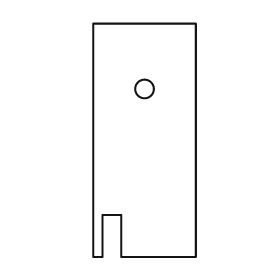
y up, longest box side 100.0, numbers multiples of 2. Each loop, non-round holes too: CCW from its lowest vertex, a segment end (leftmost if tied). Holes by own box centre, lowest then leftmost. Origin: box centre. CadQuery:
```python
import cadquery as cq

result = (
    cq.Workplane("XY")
    .moveTo(-22.0, -50.0)
    .lineTo(-18.0, -50.0)
    .lineTo(-18.0, -32.0)
    .lineTo(-10.0, -32.0)
    .lineTo(-10.0, -50.0)
    .lineTo(22.0, -50.0)
    .lineTo(22.0, 50.0)
    .lineTo(-22.0, 50.0)
    .close()
    .moveTo(0.0, 22.0)
    .circle(4.0)
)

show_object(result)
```